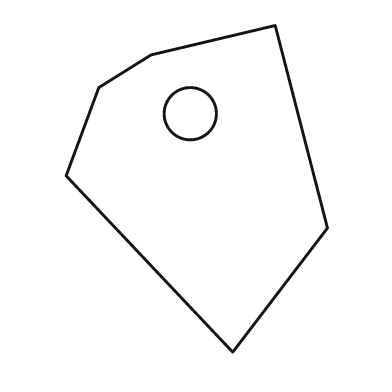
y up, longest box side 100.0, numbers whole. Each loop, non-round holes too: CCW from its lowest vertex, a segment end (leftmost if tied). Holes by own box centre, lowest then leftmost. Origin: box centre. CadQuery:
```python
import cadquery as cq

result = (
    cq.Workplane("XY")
    .moveTo(11.0, -50.0)
    .lineTo(40.0, -12.0)
    .lineTo(24.0, 50.0)
    .lineTo(-14.0, 41.0)
    .lineTo(-30.0, 31.0)
    .lineTo(-40.0, 4.0)
    .close()
    .moveTo(-2.0, 23.0)
    .circle(8.0)
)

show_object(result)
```